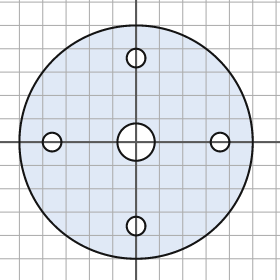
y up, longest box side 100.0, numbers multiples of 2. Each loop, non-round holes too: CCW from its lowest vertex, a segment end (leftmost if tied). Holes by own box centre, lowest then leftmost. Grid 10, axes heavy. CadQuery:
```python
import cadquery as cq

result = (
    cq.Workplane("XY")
    .moveTo(0.0, 0.0)
    .circle(50.0)
    .moveTo(0.0, -36.0)
    .circle(4.0)
    .moveTo(-36.0, 0.0)
    .circle(4.0)
    .moveTo(0.0, 0.0)
    .circle(8.0)
    .moveTo(36.0, 0.0)
    .circle(4.0)
    .moveTo(0.0, 36.0)
    .circle(4.0)
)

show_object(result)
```